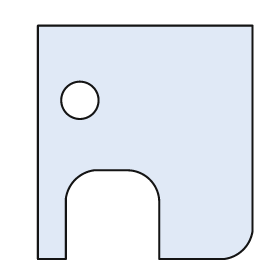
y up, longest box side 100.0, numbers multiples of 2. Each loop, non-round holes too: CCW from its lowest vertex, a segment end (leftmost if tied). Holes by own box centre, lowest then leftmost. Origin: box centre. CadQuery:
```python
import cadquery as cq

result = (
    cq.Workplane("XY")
    .moveTo(-46.0, -50.0)
    .lineTo(-34.0, -50.0)
    .lineTo(-34.0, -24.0)
    .threePointArc((-30.0, -16.0), (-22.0, -12.0))
    .lineTo(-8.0, -12.0)
    .threePointArc((2.0, -16.0), (6.0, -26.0))
    .lineTo(6.0, -50.0)
    .lineTo(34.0, -50.0)
    .threePointArc((42.0, -46.0), (46.0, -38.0))
    .lineTo(46.0, 50.0)
    .lineTo(-46.0, 50.0)
    .close()
    .moveTo(-28.0, 18.0)
    .circle(8.0)
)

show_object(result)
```